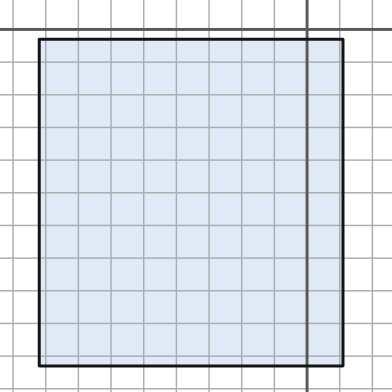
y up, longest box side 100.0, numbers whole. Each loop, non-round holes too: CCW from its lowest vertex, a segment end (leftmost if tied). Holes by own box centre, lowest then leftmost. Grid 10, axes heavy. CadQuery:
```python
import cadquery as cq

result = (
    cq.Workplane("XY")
    .moveTo(-82.0, -103.0)
    .lineTo(11.0, -103.0)
    .lineTo(11.0, -3.0)
    .lineTo(-82.0, -3.0)
    .close()
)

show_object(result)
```